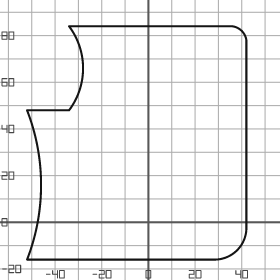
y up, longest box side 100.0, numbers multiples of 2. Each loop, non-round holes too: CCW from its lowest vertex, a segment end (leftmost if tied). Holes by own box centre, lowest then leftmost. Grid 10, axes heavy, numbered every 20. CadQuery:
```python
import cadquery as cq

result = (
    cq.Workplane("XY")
    .moveTo(-52.0, -16.0)
    .lineTo(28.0, -16.0)
    .threePointArc((38.0, -12.0), (42.0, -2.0))
    .lineTo(42.0, 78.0)
    .threePointArc((40.0, 82.0), (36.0, 84.0))
    .lineTo(-34.0, 84.0)
    .threePointArc((-28.0, 66.0), (-34.0, 48.0))
    .lineTo(-52.0, 48.0)
    .threePointArc((-46.0, 16.0), (-52.0, -16.0))
    .close()
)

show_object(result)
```